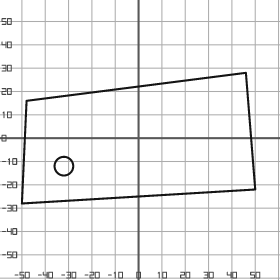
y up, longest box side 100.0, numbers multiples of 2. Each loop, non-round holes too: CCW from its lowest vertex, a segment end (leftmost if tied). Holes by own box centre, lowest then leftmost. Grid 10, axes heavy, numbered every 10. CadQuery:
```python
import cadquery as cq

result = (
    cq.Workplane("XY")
    .moveTo(-50.0, -28.0)
    .lineTo(50.0, -22.0)
    .lineTo(46.0, 28.0)
    .lineTo(-48.0, 16.0)
    .close()
    .moveTo(-32.0, -12.0)
    .circle(4.0)
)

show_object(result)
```